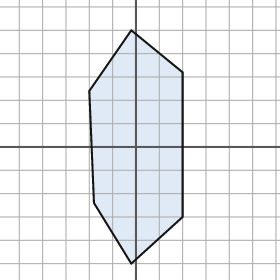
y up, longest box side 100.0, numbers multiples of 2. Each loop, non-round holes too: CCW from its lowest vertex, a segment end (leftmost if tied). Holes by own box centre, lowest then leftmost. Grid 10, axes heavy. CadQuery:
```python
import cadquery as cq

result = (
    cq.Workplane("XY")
    .moveTo(-2.0, -50.0)
    .lineTo(20.0, -30.0)
    .lineTo(20.0, 32.0)
    .lineTo(-2.0, 50.0)
    .lineTo(-20.0, 24.0)
    .lineTo(-18.0, -24.0)
    .close()
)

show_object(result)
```